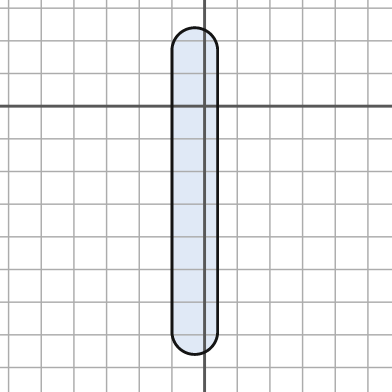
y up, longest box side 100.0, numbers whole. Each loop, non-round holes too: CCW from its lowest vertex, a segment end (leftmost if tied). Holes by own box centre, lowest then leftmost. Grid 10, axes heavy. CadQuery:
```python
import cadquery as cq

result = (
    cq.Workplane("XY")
    .moveTo(-10.0, -69.0)
    .threePointArc((-3.0, -76.0), (4.0, -69.0))
    .lineTo(4.0, 17.0)
    .threePointArc((-3.0, 24.0), (-10.0, 17.0))
    .close()
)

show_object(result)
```